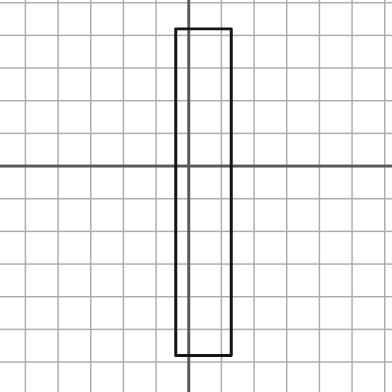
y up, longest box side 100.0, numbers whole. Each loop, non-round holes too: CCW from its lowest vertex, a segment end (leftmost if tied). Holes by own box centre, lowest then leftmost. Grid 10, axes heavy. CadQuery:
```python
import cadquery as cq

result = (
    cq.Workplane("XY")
    .moveTo(-4.0, -58.0)
    .lineTo(13.0, -58.0)
    .lineTo(13.0, 42.0)
    .lineTo(-4.0, 42.0)
    .close()
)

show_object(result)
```